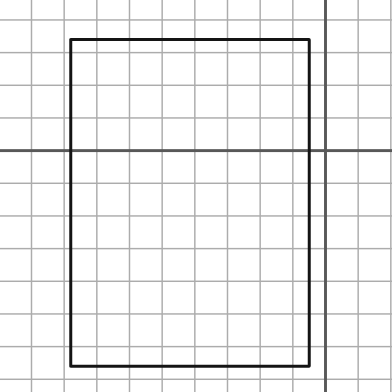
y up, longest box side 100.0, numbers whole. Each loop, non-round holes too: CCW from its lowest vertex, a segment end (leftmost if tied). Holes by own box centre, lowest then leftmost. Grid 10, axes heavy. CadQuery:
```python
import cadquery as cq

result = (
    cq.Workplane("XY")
    .moveTo(-78.0, -66.0)
    .lineTo(-5.0, -66.0)
    .lineTo(-5.0, 34.0)
    .lineTo(-78.0, 34.0)
    .close()
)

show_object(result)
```